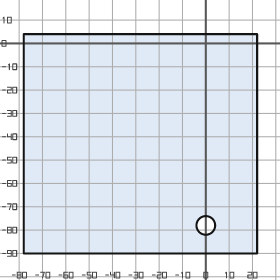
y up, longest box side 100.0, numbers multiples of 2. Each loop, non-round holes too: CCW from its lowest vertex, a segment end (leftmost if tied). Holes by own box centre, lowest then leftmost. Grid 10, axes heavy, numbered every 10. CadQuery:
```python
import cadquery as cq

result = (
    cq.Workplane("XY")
    .moveTo(-78.0, -90.0)
    .lineTo(22.0, -90.0)
    .lineTo(22.0, 4.0)
    .lineTo(-78.0, 4.0)
    .close()
    .moveTo(0.0, -78.0)
    .circle(4.0)
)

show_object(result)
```